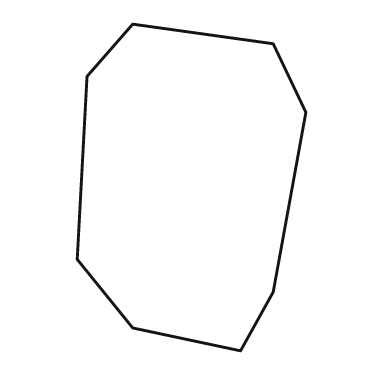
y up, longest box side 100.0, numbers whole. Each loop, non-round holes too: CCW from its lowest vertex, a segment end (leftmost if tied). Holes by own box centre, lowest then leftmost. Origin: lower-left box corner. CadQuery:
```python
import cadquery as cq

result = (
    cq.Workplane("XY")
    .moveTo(50.0, 0.0)
    .lineTo(60.0, 18.0)
    .lineTo(70.0, 73.0)
    .lineTo(60.0, 94.0)
    .lineTo(17.0, 100.0)
    .lineTo(3.0, 84.0)
    .lineTo(0.0, 28.0)
    .lineTo(17.0, 7.0)
    .close()
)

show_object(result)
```